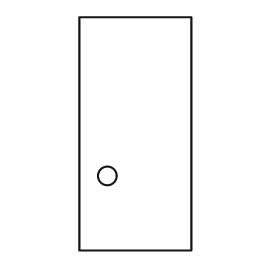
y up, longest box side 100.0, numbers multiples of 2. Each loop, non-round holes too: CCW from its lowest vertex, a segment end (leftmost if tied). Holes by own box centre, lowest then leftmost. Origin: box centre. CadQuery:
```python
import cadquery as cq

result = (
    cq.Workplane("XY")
    .moveTo(-24.0, -50.0)
    .lineTo(24.0, -50.0)
    .lineTo(24.0, 50.0)
    .lineTo(-24.0, 50.0)
    .close()
    .moveTo(-12.0, -18.0)
    .circle(4.0)
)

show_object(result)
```